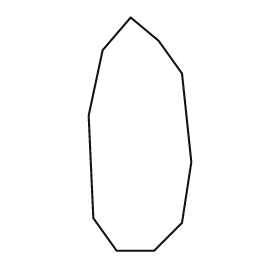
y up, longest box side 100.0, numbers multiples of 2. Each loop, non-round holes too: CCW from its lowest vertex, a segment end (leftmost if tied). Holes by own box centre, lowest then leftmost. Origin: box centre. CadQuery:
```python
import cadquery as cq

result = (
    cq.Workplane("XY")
    .moveTo(-10.0, -50.0)
    .lineTo(6.0, -50.0)
    .lineTo(18.0, -38.0)
    .lineTo(22.0, -12.0)
    .lineTo(18.0, 26.0)
    .lineTo(8.0, 40.0)
    .lineTo(-4.0, 50.0)
    .lineTo(-16.0, 36.0)
    .lineTo(-22.0, 8.0)
    .lineTo(-20.0, -36.0)
    .close()
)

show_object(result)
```